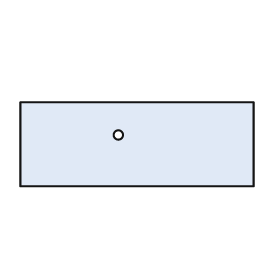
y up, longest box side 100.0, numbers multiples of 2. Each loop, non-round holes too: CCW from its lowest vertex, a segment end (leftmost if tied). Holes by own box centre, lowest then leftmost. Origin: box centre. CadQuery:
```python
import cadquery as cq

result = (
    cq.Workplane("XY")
    .moveTo(-50.0, -18.0)
    .lineTo(50.0, -18.0)
    .lineTo(50.0, 18.0)
    .lineTo(-50.0, 18.0)
    .close()
    .moveTo(-8.0, 4.0)
    .circle(2.0)
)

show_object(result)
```